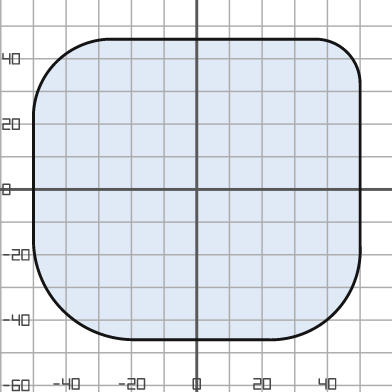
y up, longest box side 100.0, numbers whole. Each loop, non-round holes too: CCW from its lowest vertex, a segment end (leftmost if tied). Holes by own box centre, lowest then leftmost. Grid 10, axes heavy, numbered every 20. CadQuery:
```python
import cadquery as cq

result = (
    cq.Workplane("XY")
    .moveTo(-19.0, -46.0)
    .lineTo(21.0, -46.0)
    .threePointArc((42.0, -38.0), (50.0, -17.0))
    .lineTo(50.0, 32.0)
    .threePointArc((46.0, 42.0), (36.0, 46.0))
    .lineTo(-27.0, 46.0)
    .threePointArc((-43.0, 39.0), (-50.0, 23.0))
    .lineTo(-50.0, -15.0)
    .threePointArc((-41.0, -37.0), (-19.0, -46.0))
    .close()
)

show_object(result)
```